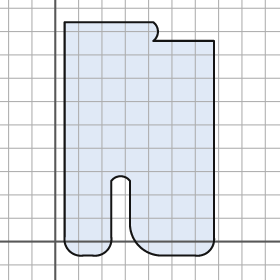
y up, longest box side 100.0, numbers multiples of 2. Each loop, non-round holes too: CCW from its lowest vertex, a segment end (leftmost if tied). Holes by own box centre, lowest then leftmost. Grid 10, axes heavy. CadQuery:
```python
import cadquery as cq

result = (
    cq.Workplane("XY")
    .moveTo(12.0, -6.0)
    .lineTo(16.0, -6.0)
    .threePointArc((22.0, -4.0), (24.0, 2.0))
    .lineTo(24.0, 26.0)
    .threePointArc((28.0, 28.0), (32.0, 26.0))
    .lineTo(32.0, 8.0)
    .threePointArc((36.0, -2.0), (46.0, -6.0))
    .lineTo(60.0, -6.0)
    .threePointArc((66.0, -4.0), (68.0, 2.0))
    .lineTo(68.0, 86.0)
    .lineTo(42.0, 86.0)
    .threePointArc((44.0, 90.0), (42.0, 94.0))
    .lineTo(4.0, 94.0)
    .lineTo(4.0, 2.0)
    .threePointArc((6.0, -4.0), (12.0, -6.0))
    .close()
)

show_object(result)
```